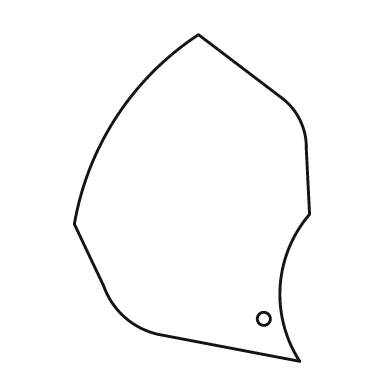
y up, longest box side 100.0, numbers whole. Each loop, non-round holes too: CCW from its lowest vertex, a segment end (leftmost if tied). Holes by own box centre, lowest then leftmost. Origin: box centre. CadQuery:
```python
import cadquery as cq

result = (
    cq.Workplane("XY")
    .moveTo(33.0, -50.0)
    .threePointArc((27.0, -27.0), (36.0, -5.0))
    .lineTo(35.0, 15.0)
    .threePointArc((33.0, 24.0), (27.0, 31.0))
    .lineTo(2.0, 50.0)
    .threePointArc((-23.0, 25.0), (-36.0, -8.0))
    .lineTo(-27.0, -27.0)
    .threePointArc((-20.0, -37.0), (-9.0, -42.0))
    .close()
    .moveTo(22.0, -37.0)
    .circle(2.0)
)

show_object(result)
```